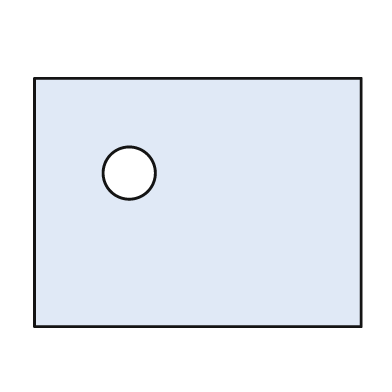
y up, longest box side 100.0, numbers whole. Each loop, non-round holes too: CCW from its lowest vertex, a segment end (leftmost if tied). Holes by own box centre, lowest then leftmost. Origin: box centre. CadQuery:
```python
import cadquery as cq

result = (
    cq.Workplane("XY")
    .moveTo(-50.0, -38.0)
    .lineTo(50.0, -38.0)
    .lineTo(50.0, 38.0)
    .lineTo(-50.0, 38.0)
    .close()
    .moveTo(-21.0, 9.0)
    .circle(8.0)
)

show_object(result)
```